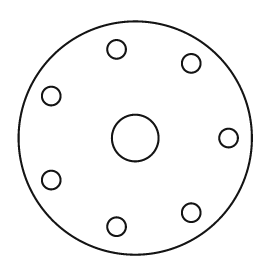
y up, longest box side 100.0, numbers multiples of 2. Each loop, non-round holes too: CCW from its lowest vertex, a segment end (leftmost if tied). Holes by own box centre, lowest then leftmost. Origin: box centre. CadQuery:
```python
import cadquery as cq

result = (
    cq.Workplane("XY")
    .moveTo(0.0, 0.0)
    .circle(50.0)
    .moveTo(-8.0, -38.0)
    .circle(4.0)
    .moveTo(24.0, -32.0)
    .circle(4.0)
    .moveTo(-36.0, -18.0)
    .circle(4.0)
    .moveTo(0.0, 0.0)
    .circle(10.0)
    .moveTo(40.0, 0.0)
    .circle(4.0)
    .moveTo(-36.0, 18.0)
    .circle(4.0)
    .moveTo(24.0, 32.0)
    .circle(4.0)
    .moveTo(-8.0, 38.0)
    .circle(4.0)
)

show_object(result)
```